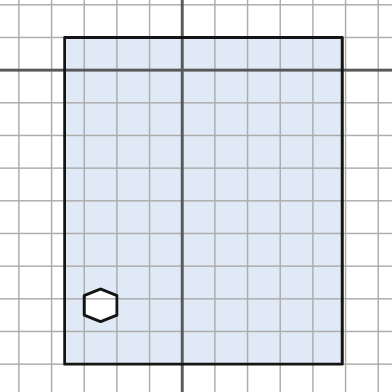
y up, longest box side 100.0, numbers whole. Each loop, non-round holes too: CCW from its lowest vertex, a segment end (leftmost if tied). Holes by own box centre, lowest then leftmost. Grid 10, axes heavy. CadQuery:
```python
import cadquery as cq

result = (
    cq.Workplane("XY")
    .moveTo(-36.0, -90.0)
    .lineTo(49.0, -90.0)
    .lineTo(49.0, 10.0)
    .lineTo(-36.0, 10.0)
    .close()
    .moveTo(-25.0, -77.0)
    .lineTo(-20.0, -75.0)
    .lineTo(-20.0, -69.0)
    .lineTo(-25.0, -67.0)
    .lineTo(-30.0, -69.0)
    .lineTo(-30.0, -75.0)
    .close()
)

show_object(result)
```